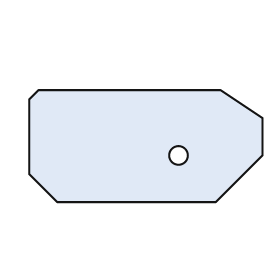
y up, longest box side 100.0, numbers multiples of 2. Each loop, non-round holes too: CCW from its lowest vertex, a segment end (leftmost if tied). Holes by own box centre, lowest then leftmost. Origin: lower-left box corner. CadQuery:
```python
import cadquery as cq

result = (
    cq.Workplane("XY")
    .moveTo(12.0, 0.0)
    .lineTo(80.0, 0.0)
    .lineTo(100.0, 20.0)
    .lineTo(100.0, 36.0)
    .lineTo(82.0, 48.0)
    .lineTo(4.0, 48.0)
    .lineTo(0.0, 44.0)
    .lineTo(0.0, 12.0)
    .close()
    .moveTo(64.0, 20.0)
    .circle(4.0)
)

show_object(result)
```